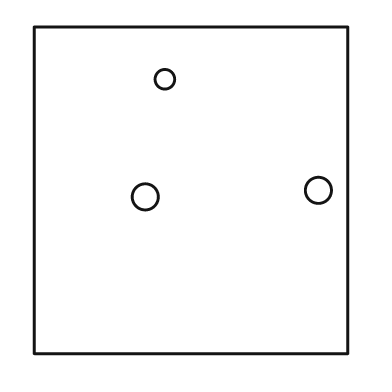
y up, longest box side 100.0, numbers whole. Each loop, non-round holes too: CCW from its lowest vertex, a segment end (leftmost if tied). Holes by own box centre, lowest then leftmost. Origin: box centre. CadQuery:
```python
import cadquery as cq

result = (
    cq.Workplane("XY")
    .moveTo(-48.0, -50.0)
    .lineTo(48.0, -50.0)
    .lineTo(48.0, 50.0)
    .lineTo(-48.0, 50.0)
    .close()
    .moveTo(-14.0, -2.0)
    .circle(4.0)
    .moveTo(39.0, 0.0)
    .circle(4.0)
    .moveTo(-8.0, 34.0)
    .circle(3.0)
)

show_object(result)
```